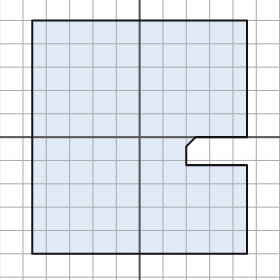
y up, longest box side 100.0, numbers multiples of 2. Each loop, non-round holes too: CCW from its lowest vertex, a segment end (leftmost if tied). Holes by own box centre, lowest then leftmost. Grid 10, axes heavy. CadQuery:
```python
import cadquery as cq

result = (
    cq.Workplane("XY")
    .moveTo(-46.0, -50.0)
    .lineTo(46.0, -50.0)
    .lineTo(46.0, -12.0)
    .lineTo(20.0, -12.0)
    .lineTo(20.0, -4.0)
    .lineTo(24.0, 0.0)
    .lineTo(46.0, 0.0)
    .lineTo(46.0, 50.0)
    .lineTo(-46.0, 50.0)
    .close()
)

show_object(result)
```